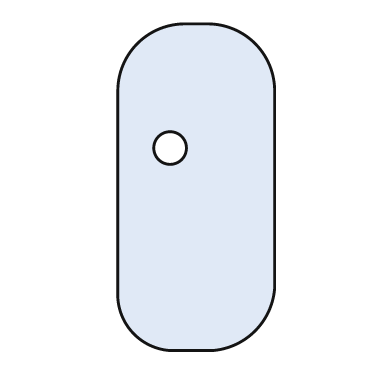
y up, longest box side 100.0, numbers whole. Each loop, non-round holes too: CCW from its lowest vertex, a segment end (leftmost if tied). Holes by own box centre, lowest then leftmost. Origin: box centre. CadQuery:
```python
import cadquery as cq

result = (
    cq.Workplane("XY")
    .moveTo(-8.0, -50.0)
    .lineTo(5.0, -50.0)
    .threePointArc((18.0, -44.0), (24.0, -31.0))
    .lineTo(24.0, 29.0)
    .threePointArc((18.0, 44.0), (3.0, 50.0))
    .lineTo(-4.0, 50.0)
    .threePointArc((-18.0, 44.0), (-24.0, 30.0))
    .lineTo(-24.0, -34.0)
    .threePointArc((-19.0, -45.0), (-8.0, -50.0))
    .close()
    .moveTo(-8.0, 12.0)
    .circle(5.0)
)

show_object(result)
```